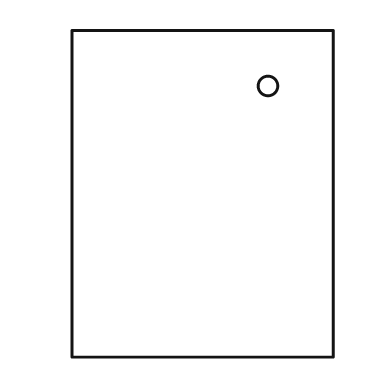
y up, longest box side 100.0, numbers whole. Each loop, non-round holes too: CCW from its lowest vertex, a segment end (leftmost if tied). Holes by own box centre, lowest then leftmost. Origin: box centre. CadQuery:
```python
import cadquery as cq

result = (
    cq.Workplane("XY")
    .moveTo(-40.0, -50.0)
    .lineTo(40.0, -50.0)
    .lineTo(40.0, 50.0)
    .lineTo(-40.0, 50.0)
    .close()
    .moveTo(20.0, 33.0)
    .circle(3.0)
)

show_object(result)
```